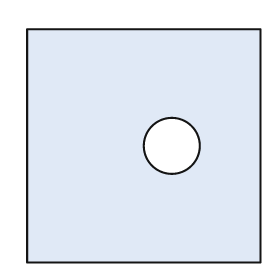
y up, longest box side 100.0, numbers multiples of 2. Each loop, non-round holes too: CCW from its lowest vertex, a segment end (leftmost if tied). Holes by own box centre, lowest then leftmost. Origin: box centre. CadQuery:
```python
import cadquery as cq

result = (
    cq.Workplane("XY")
    .moveTo(-50.0, -50.0)
    .lineTo(50.0, -50.0)
    .lineTo(50.0, 50.0)
    .lineTo(-50.0, 50.0)
    .close()
    .moveTo(12.0, 0.0)
    .circle(12.0)
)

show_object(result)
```